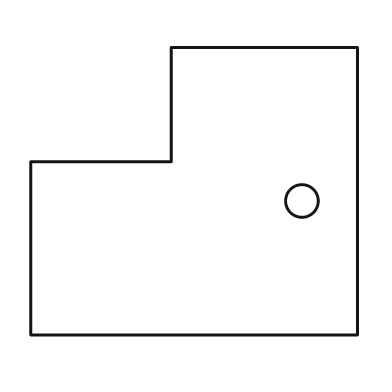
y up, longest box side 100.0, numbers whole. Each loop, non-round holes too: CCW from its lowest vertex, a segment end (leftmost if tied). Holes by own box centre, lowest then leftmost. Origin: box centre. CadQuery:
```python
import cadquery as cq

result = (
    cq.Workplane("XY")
    .moveTo(-50.0, -44.0)
    .lineTo(50.0, -44.0)
    .lineTo(50.0, 44.0)
    .lineTo(-7.0, 44.0)
    .lineTo(-7.0, 9.0)
    .lineTo(-50.0, 9.0)
    .close()
    .moveTo(33.0, -3.0)
    .circle(5.0)
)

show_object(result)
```